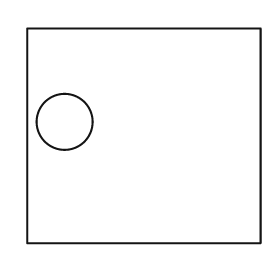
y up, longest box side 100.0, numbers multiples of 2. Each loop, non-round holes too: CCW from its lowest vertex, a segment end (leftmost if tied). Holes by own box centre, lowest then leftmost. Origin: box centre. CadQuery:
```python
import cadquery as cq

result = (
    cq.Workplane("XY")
    .moveTo(-50.0, -46.0)
    .lineTo(50.0, -46.0)
    .lineTo(50.0, 46.0)
    .lineTo(-50.0, 46.0)
    .close()
    .moveTo(-34.0, 6.0)
    .circle(12.0)
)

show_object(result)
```